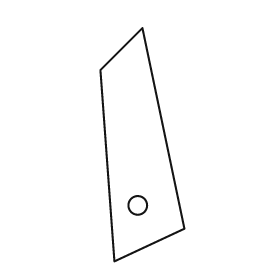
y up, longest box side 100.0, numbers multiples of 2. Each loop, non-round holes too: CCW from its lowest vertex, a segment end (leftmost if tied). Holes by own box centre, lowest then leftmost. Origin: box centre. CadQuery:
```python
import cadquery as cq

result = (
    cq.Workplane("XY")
    .moveTo(-12.0, -50.0)
    .lineTo(18.0, -36.0)
    .lineTo(0.0, 50.0)
    .lineTo(-18.0, 32.0)
    .close()
    .moveTo(-2.0, -26.0)
    .circle(4.0)
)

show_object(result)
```